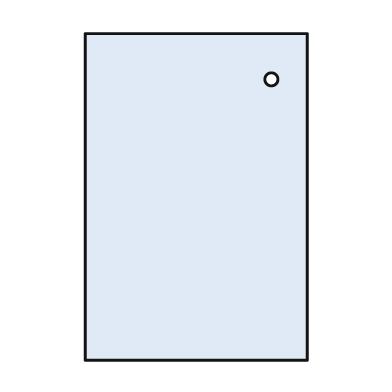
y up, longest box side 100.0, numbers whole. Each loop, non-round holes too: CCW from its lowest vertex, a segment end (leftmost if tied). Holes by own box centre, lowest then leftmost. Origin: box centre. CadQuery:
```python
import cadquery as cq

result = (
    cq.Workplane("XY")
    .moveTo(-34.0, -50.0)
    .lineTo(34.0, -50.0)
    .lineTo(34.0, 50.0)
    .lineTo(-34.0, 50.0)
    .close()
    .moveTo(23.0, 36.0)
    .circle(2.0)
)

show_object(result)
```